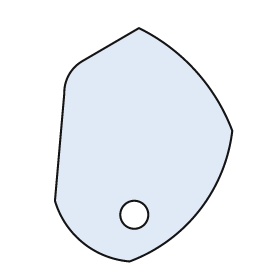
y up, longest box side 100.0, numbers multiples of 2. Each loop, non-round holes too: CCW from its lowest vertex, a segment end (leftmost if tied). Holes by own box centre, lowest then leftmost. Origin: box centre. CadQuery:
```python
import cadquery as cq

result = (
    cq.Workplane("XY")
    .moveTo(-6.0, -50.0)
    .threePointArc((24.0, -28.0), (38.0, 6.0))
    .threePointArc((22.0, 32.0), (-2.0, 50.0))
    .lineTo(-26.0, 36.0)
    .threePointArc((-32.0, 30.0), (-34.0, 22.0))
    .lineTo(-38.0, -24.0)
    .threePointArc((-26.0, -42.0), (-6.0, -50.0))
    .close()
    .moveTo(-4.0, -30.0)
    .circle(6.0)
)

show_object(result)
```